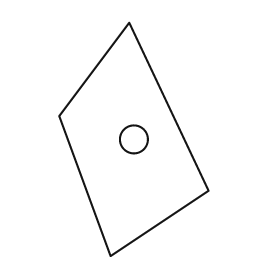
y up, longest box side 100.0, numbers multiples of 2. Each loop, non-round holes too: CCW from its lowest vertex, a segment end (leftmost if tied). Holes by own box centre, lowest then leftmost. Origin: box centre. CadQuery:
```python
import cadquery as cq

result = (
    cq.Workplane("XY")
    .moveTo(-10.0, -50.0)
    .lineTo(32.0, -22.0)
    .lineTo(-2.0, 50.0)
    .lineTo(-32.0, 10.0)
    .close()
    .moveTo(0.0, 0.0)
    .circle(6.0)
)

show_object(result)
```